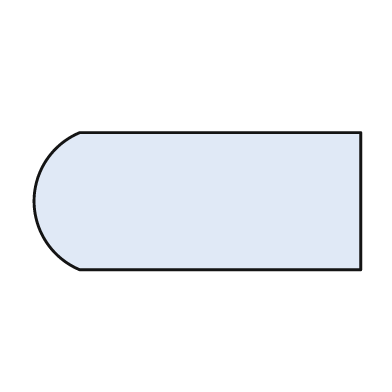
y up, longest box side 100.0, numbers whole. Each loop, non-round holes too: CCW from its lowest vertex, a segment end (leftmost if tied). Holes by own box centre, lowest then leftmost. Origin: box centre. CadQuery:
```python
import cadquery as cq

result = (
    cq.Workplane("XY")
    .moveTo(-36.0, -21.0)
    .lineTo(50.0, -21.0)
    .lineTo(50.0, 21.0)
    .lineTo(-36.0, 21.0)
    .threePointArc((-50.0, 0.0), (-36.0, -21.0))
    .close()
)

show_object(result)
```